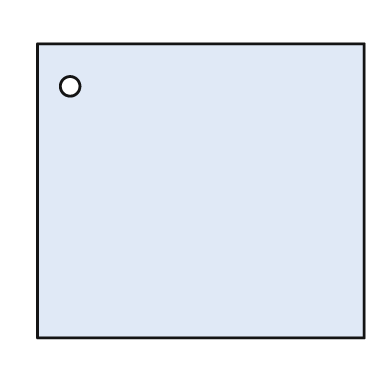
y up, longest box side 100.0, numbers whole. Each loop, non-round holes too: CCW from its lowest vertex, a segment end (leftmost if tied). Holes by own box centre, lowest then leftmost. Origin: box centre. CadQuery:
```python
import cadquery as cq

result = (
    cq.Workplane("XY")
    .moveTo(-50.0, -45.0)
    .lineTo(50.0, -45.0)
    .lineTo(50.0, 45.0)
    .lineTo(-50.0, 45.0)
    .close()
    .moveTo(-40.0, 32.0)
    .circle(3.0)
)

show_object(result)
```